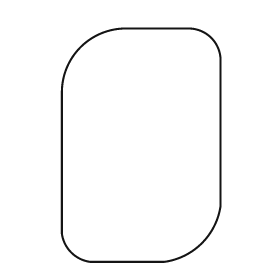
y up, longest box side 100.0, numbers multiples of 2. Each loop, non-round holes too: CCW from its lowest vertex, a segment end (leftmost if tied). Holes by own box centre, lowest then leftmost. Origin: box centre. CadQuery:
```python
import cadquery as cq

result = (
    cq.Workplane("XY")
    .moveTo(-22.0, -50.0)
    .lineTo(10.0, -50.0)
    .threePointArc((26.0, -42.0), (34.0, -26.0))
    .lineTo(34.0, 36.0)
    .threePointArc((30.0, 46.0), (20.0, 50.0))
    .lineTo(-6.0, 50.0)
    .threePointArc((-26.0, 42.0), (-34.0, 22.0))
    .lineTo(-34.0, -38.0)
    .threePointArc((-30.0, -46.0), (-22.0, -50.0))
    .close()
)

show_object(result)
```